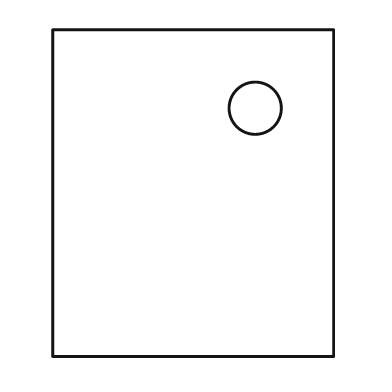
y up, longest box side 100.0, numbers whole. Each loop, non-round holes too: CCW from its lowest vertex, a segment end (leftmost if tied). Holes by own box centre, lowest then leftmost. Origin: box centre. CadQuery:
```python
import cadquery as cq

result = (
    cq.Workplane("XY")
    .moveTo(-43.0, -50.0)
    .lineTo(43.0, -50.0)
    .lineTo(43.0, 50.0)
    .lineTo(-43.0, 50.0)
    .close()
    .moveTo(19.0, 26.0)
    .circle(8.0)
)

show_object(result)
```